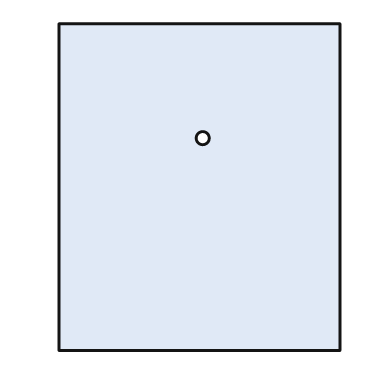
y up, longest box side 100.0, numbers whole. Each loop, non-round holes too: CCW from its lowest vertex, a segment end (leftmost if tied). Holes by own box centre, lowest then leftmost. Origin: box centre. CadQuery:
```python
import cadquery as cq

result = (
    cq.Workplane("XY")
    .moveTo(-43.0, -50.0)
    .lineTo(43.0, -50.0)
    .lineTo(43.0, 50.0)
    .lineTo(-43.0, 50.0)
    .close()
    .moveTo(1.0, 15.0)
    .circle(2.0)
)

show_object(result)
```